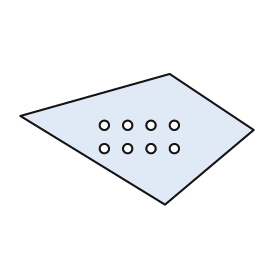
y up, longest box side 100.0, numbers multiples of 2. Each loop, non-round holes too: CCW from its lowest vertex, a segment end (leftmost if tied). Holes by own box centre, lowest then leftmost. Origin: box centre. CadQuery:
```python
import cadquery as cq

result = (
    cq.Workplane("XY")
    .moveTo(12.0, -28.0)
    .lineTo(50.0, 4.0)
    .lineTo(14.0, 28.0)
    .lineTo(-50.0, 10.0)
    .close()
    .moveTo(-14.0, -4.0)
    .circle(2.0)
    .moveTo(-4.0, -4.0)
    .circle(2.0)
    .moveTo(6.0, -4.0)
    .circle(2.0)
    .moveTo(16.0, -4.0)
    .circle(2.0)
    .moveTo(-14.0, 6.0)
    .circle(2.0)
    .moveTo(-4.0, 6.0)
    .circle(2.0)
    .moveTo(6.0, 6.0)
    .circle(2.0)
    .moveTo(16.0, 6.0)
    .circle(2.0)
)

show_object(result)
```